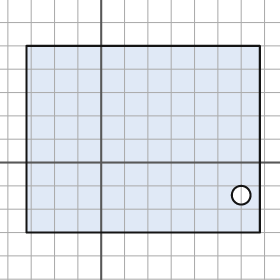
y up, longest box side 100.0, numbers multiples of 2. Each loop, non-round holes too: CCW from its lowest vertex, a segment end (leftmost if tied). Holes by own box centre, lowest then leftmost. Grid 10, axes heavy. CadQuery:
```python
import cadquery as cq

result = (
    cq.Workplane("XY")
    .moveTo(-32.0, -30.0)
    .lineTo(68.0, -30.0)
    .lineTo(68.0, 50.0)
    .lineTo(-32.0, 50.0)
    .close()
    .moveTo(60.0, -14.0)
    .circle(4.0)
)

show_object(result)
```